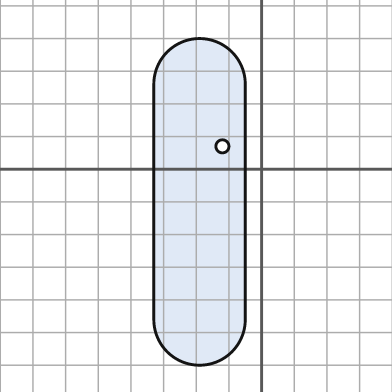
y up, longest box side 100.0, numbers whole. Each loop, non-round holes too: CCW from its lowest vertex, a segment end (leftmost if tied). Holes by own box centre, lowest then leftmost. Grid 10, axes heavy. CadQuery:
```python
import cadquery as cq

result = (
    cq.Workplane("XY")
    .moveTo(-33.0, -46.0)
    .threePointArc((-19.0, -60.0), (-5.0, -46.0))
    .lineTo(-5.0, 26.0)
    .threePointArc((-19.0, 40.0), (-33.0, 26.0))
    .close()
    .moveTo(-12.0, 7.0)
    .circle(2.0)
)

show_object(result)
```